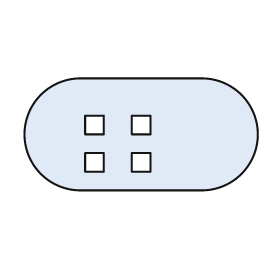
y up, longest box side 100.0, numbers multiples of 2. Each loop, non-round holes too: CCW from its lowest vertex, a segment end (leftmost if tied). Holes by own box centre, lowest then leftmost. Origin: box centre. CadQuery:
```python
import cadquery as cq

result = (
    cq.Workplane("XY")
    .moveTo(-26.0, -24.0)
    .lineTo(26.0, -24.0)
    .threePointArc((50.0, 0.0), (26.0, 24.0))
    .lineTo(-26.0, 24.0)
    .threePointArc((-50.0, 0.0), (-26.0, -24.0))
    .close()
    .moveTo(-24.0, -16.0)
    .lineTo(-16.0, -16.0)
    .lineTo(-16.0, -8.0)
    .lineTo(-24.0, -8.0)
    .close()
    .moveTo(-4.0, -16.0)
    .lineTo(4.0, -16.0)
    .lineTo(4.0, -8.0)
    .lineTo(-4.0, -8.0)
    .close()
    .moveTo(-24.0, 0.0)
    .lineTo(-16.0, 0.0)
    .lineTo(-16.0, 8.0)
    .lineTo(-24.0, 8.0)
    .close()
    .moveTo(-4.0, 0.0)
    .lineTo(4.0, 0.0)
    .lineTo(4.0, 8.0)
    .lineTo(-4.0, 8.0)
    .close()
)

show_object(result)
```